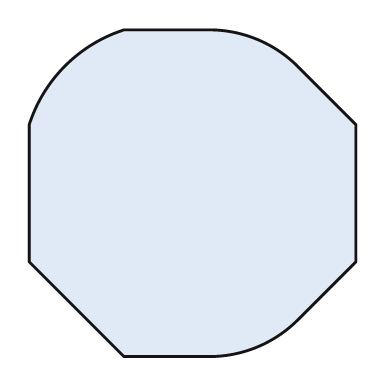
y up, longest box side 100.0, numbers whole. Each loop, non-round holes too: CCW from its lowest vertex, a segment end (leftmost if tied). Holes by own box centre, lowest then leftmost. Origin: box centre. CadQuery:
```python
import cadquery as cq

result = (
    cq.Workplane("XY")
    .moveTo(-21.0, -50.0)
    .lineTo(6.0, -50.0)
    .threePointArc((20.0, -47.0), (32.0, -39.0))
    .lineTo(50.0, -21.0)
    .lineTo(50.0, 21.0)
    .lineTo(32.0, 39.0)
    .threePointArc((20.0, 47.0), (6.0, 50.0))
    .lineTo(-21.0, 50.0)
    .threePointArc((-39.0, 39.0), (-50.0, 21.0))
    .lineTo(-50.0, -21.0)
    .close()
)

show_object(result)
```